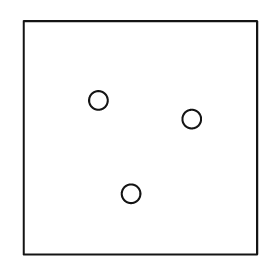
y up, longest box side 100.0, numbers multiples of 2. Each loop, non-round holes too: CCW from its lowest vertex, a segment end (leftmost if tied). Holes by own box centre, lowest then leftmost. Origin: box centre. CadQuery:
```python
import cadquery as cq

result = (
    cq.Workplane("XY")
    .moveTo(-50.0, -50.0)
    .lineTo(50.0, -50.0)
    .lineTo(50.0, 50.0)
    .lineTo(-50.0, 50.0)
    .close()
    .moveTo(-4.0, -24.0)
    .circle(4.0)
    .moveTo(22.0, 8.0)
    .circle(4.0)
    .moveTo(-18.0, 16.0)
    .circle(4.0)
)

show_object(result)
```